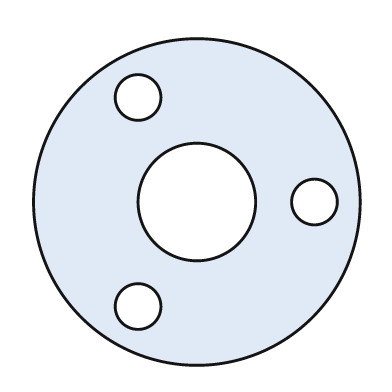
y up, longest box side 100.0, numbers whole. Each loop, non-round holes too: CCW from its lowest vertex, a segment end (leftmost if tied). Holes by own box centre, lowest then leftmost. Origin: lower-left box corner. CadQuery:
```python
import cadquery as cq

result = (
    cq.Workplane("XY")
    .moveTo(50.0, 50.0)
    .circle(50.0)
    .moveTo(32.0, 18.0)
    .circle(7.0)
    .moveTo(50.0, 50.0)
    .circle(18.0)
    .moveTo(86.0, 50.0)
    .circle(7.0)
    .moveTo(32.0, 82.0)
    .circle(7.0)
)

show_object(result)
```